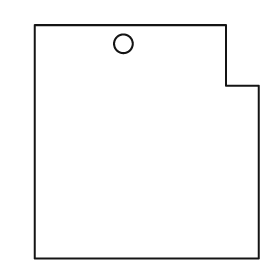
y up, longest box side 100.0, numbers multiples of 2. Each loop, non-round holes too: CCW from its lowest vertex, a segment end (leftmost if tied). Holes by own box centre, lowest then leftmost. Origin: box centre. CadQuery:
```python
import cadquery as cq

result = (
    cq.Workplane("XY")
    .moveTo(-48.0, -50.0)
    .lineTo(48.0, -50.0)
    .lineTo(48.0, 24.0)
    .lineTo(34.0, 24.0)
    .lineTo(34.0, 50.0)
    .lineTo(-48.0, 50.0)
    .close()
    .moveTo(-10.0, 42.0)
    .circle(4.0)
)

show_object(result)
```